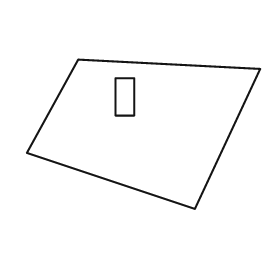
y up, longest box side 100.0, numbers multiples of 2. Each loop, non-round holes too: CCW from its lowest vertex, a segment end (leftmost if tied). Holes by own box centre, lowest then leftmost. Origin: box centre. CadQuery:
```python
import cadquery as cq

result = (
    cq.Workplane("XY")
    .moveTo(22.0, -32.0)
    .lineTo(50.0, 28.0)
    .lineTo(-28.0, 32.0)
    .lineTo(-50.0, -8.0)
    .close()
    .moveTo(-12.0, 8.0)
    .lineTo(-4.0, 8.0)
    .lineTo(-4.0, 24.0)
    .lineTo(-12.0, 24.0)
    .close()
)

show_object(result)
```